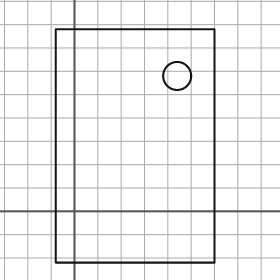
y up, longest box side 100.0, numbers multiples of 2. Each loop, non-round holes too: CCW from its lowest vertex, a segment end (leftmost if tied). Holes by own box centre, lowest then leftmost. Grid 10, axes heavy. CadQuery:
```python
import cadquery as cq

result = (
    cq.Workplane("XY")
    .moveTo(-8.0, -22.0)
    .lineTo(60.0, -22.0)
    .lineTo(60.0, 78.0)
    .lineTo(-8.0, 78.0)
    .close()
    .moveTo(44.0, 58.0)
    .circle(6.0)
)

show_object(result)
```